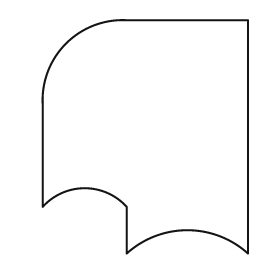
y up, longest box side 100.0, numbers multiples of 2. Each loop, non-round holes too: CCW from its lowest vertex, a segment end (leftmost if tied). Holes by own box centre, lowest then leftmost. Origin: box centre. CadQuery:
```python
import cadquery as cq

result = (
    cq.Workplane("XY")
    .moveTo(-8.0, -50.0)
    .threePointArc((18.0, -40.0), (44.0, -50.0))
    .lineTo(44.0, 50.0)
    .lineTo(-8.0, 50.0)
    .threePointArc((-34.0, 40.0), (-44.0, 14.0))
    .lineTo(-44.0, -30.0)
    .threePointArc((-26.0, -22.0), (-8.0, -30.0))
    .close()
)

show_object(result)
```